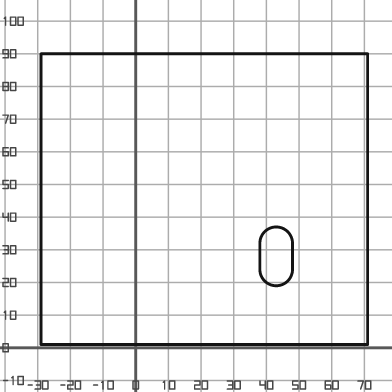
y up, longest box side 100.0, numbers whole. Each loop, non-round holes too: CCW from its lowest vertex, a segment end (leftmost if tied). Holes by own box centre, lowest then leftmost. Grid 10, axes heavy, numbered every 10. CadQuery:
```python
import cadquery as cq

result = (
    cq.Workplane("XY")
    .moveTo(-29.0, 1.0)
    .lineTo(71.0, 1.0)
    .lineTo(71.0, 90.0)
    .lineTo(-29.0, 90.0)
    .close()
    .moveTo(38.0, 24.0)
    .threePointArc((43.0, 19.0), (48.0, 24.0))
    .lineTo(48.0, 32.0)
    .threePointArc((43.0, 37.0), (38.0, 32.0))
    .close()
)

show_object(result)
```